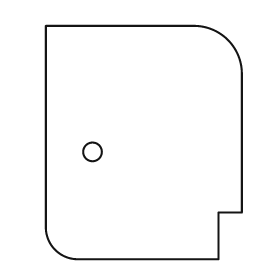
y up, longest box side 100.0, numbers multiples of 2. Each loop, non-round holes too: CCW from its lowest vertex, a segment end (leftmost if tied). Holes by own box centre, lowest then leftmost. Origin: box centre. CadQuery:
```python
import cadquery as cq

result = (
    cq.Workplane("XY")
    .moveTo(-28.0, -50.0)
    .lineTo(32.0, -50.0)
    .lineTo(32.0, -30.0)
    .lineTo(42.0, -30.0)
    .lineTo(42.0, 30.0)
    .threePointArc((36.0, 44.0), (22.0, 50.0))
    .lineTo(-42.0, 50.0)
    .lineTo(-42.0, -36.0)
    .threePointArc((-38.0, -46.0), (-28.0, -50.0))
    .close()
    .moveTo(-22.0, -4.0)
    .circle(4.0)
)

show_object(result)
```